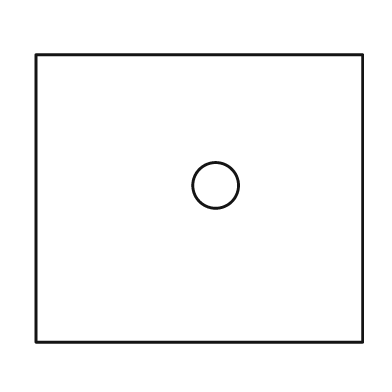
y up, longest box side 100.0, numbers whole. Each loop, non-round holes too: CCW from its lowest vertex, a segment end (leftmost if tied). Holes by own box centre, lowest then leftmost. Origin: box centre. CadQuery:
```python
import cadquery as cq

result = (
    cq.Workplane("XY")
    .moveTo(-50.0, -44.0)
    .lineTo(50.0, -44.0)
    .lineTo(50.0, 44.0)
    .lineTo(-50.0, 44.0)
    .close()
    .moveTo(5.0, 4.0)
    .circle(7.0)
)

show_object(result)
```